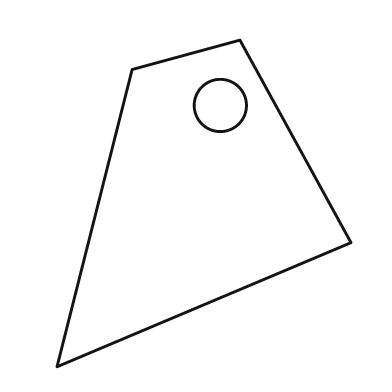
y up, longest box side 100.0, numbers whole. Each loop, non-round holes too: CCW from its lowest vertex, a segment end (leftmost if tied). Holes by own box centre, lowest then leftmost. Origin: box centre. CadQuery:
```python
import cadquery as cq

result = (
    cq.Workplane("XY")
    .moveTo(-45.0, -50.0)
    .lineTo(45.0, -12.0)
    .lineTo(11.0, 50.0)
    .lineTo(-22.0, 41.0)
    .close()
    .moveTo(5.0, 30.0)
    .circle(8.0)
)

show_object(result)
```